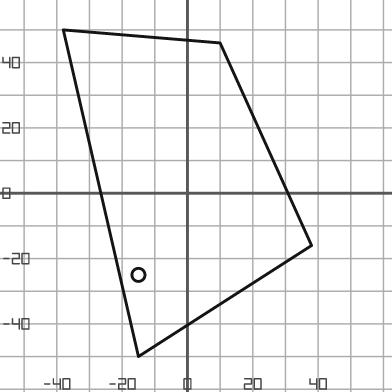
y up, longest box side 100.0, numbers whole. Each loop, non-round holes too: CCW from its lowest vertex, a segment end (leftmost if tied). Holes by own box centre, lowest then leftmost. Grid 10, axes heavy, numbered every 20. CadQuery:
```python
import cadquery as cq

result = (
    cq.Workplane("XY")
    .moveTo(-15.0, -50.0)
    .lineTo(38.0, -16.0)
    .lineTo(10.0, 46.0)
    .lineTo(-38.0, 50.0)
    .close()
    .moveTo(-15.0, -25.0)
    .circle(2.0)
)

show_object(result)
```